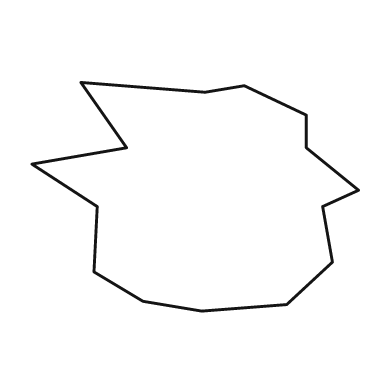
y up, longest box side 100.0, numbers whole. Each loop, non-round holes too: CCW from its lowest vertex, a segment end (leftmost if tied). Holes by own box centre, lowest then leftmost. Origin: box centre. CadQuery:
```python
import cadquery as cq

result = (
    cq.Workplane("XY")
    .moveTo(2.0, -35.0)
    .lineTo(28.0, -33.0)
    .lineTo(42.0, -20.0)
    .lineTo(39.0, -3.0)
    .lineTo(50.0, 2.0)
    .lineTo(34.0, 15.0)
    .lineTo(34.0, 25.0)
    .lineTo(15.0, 34.0)
    .lineTo(3.0, 32.0)
    .lineTo(-35.0, 35.0)
    .lineTo(-21.0, 15.0)
    .lineTo(-50.0, 10.0)
    .lineTo(-30.0, -3.0)
    .lineTo(-31.0, -23.0)
    .lineTo(-16.0, -32.0)
    .close()
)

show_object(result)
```